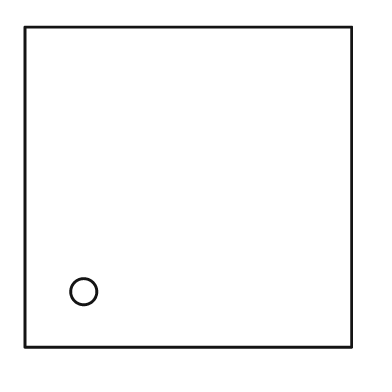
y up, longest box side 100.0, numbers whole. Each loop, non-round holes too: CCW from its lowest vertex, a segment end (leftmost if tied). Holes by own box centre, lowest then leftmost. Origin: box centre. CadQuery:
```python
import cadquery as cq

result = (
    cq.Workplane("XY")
    .moveTo(-50.0, -49.0)
    .lineTo(50.0, -49.0)
    .lineTo(50.0, 49.0)
    .lineTo(-50.0, 49.0)
    .close()
    .moveTo(-32.0, -32.0)
    .circle(4.0)
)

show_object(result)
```